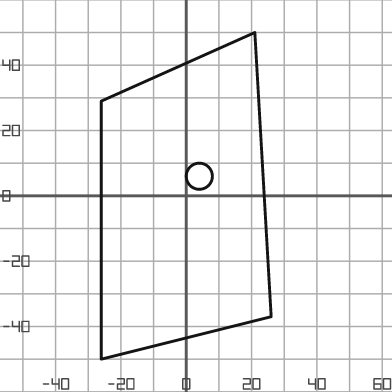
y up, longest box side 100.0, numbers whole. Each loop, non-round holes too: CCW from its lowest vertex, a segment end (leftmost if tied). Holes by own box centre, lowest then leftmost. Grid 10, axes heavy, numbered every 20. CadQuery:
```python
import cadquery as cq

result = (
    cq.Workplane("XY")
    .moveTo(-26.0, -50.0)
    .lineTo(26.0, -37.0)
    .lineTo(21.0, 50.0)
    .lineTo(-26.0, 29.0)
    .close()
    .moveTo(4.0, 6.0)
    .circle(4.0)
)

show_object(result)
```